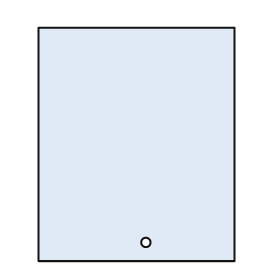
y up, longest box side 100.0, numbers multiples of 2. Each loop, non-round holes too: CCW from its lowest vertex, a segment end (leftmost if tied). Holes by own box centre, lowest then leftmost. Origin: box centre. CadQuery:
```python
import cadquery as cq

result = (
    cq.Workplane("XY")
    .moveTo(-42.0, -50.0)
    .lineTo(42.0, -50.0)
    .lineTo(42.0, 50.0)
    .lineTo(-42.0, 50.0)
    .close()
    .moveTo(4.0, -42.0)
    .circle(2.0)
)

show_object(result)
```